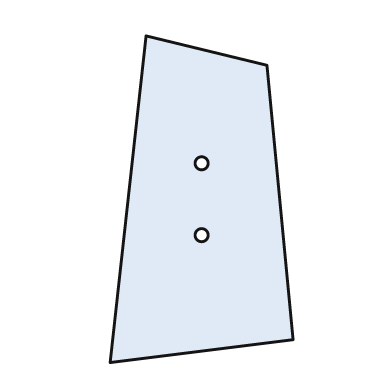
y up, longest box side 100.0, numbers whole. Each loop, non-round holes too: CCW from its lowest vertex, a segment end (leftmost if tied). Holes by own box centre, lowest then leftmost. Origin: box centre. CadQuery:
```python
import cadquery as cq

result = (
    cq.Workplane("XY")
    .moveTo(-28.0, -50.0)
    .lineTo(28.0, -43.0)
    .lineTo(20.0, 41.0)
    .lineTo(-17.0, 50.0)
    .close()
    .moveTo(0.0, -11.0)
    .circle(2.0)
    .moveTo(0.0, 11.0)
    .circle(2.0)
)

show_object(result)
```